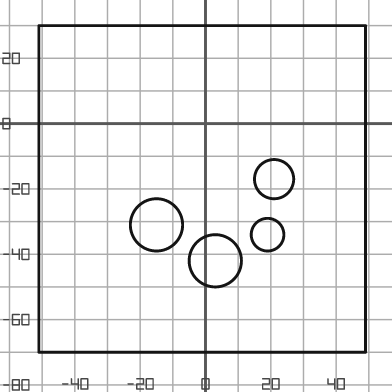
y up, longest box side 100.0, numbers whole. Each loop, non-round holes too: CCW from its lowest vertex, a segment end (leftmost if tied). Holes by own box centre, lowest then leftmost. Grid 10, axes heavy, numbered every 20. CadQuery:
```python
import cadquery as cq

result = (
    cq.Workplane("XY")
    .moveTo(-51.0, -70.0)
    .lineTo(49.0, -70.0)
    .lineTo(49.0, 30.0)
    .lineTo(-51.0, 30.0)
    .close()
    .moveTo(3.0, -42.0)
    .circle(8.0)
    .moveTo(19.0, -34.0)
    .circle(5.0)
    .moveTo(-15.0, -31.0)
    .circle(8.0)
    .moveTo(21.0, -17.0)
    .circle(6.0)
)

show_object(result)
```